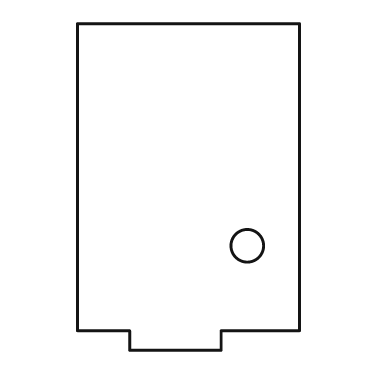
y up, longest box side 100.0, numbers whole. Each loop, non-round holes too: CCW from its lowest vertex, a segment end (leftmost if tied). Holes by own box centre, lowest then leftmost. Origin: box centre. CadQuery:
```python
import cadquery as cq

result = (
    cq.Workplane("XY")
    .moveTo(-18.0, -50.0)
    .lineTo(10.0, -50.0)
    .lineTo(10.0, -44.0)
    .lineTo(34.0, -44.0)
    .lineTo(34.0, 50.0)
    .lineTo(-34.0, 50.0)
    .lineTo(-34.0, -44.0)
    .lineTo(-18.0, -44.0)
    .close()
    .moveTo(18.0, -18.0)
    .circle(5.0)
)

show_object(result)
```